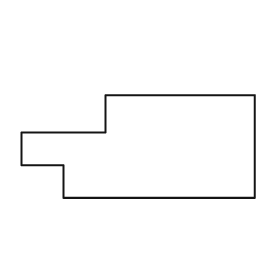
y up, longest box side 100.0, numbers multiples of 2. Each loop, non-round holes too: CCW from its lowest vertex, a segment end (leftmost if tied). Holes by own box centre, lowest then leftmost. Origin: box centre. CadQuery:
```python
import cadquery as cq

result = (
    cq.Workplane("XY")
    .moveTo(-32.0, -22.0)
    .lineTo(50.0, -22.0)
    .lineTo(50.0, 22.0)
    .lineTo(-14.0, 22.0)
    .lineTo(-14.0, 6.0)
    .lineTo(-50.0, 6.0)
    .lineTo(-50.0, -8.0)
    .lineTo(-32.0, -8.0)
    .close()
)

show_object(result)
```